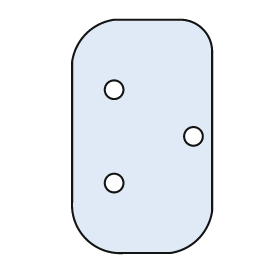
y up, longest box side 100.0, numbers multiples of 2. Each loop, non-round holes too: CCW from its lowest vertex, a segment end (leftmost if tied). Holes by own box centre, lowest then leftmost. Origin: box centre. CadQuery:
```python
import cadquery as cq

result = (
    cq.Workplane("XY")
    .moveTo(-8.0, -50.0)
    .lineTo(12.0, -50.0)
    .threePointArc((24.0, -44.0), (30.0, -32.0))
    .lineTo(30.0, 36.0)
    .threePointArc((26.0, 46.0), (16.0, 50.0))
    .lineTo(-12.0, 50.0)
    .threePointArc((-24.0, 44.0), (-30.0, 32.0))
    .lineTo(-30.0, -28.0)
    .threePointArc((-24.0, -44.0), (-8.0, -50.0))
    .close()
    .moveTo(-12.0, -20.0)
    .circle(4.0)
    .moveTo(22.0, 0.0)
    .circle(4.0)
    .moveTo(-12.0, 20.0)
    .circle(4.0)
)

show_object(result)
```